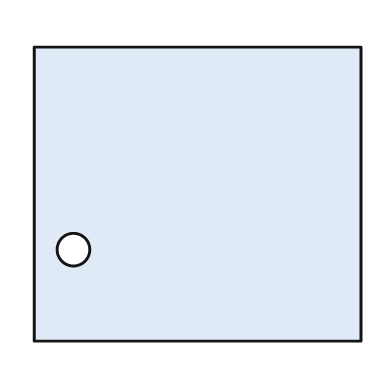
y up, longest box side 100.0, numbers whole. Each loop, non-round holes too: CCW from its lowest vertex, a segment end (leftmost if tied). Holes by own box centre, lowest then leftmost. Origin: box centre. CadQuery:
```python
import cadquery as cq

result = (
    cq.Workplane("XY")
    .moveTo(-50.0, -45.0)
    .lineTo(50.0, -45.0)
    .lineTo(50.0, 45.0)
    .lineTo(-50.0, 45.0)
    .close()
    .moveTo(-38.0, -17.0)
    .circle(5.0)
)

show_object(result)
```